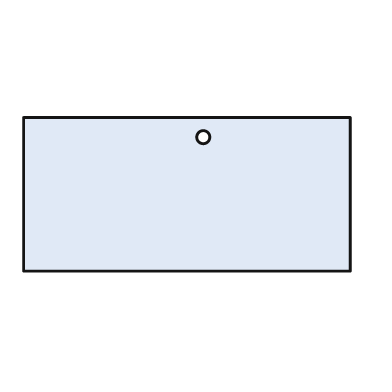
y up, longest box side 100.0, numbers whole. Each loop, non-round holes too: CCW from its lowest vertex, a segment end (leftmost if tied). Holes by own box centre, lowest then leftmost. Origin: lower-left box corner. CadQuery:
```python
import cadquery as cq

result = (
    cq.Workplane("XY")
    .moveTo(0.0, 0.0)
    .lineTo(100.0, 0.0)
    .lineTo(100.0, 47.0)
    .lineTo(0.0, 47.0)
    .close()
    .moveTo(55.0, 41.0)
    .circle(2.0)
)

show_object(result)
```